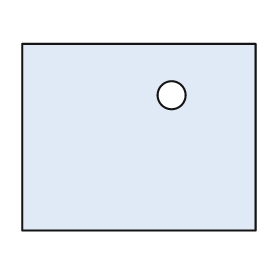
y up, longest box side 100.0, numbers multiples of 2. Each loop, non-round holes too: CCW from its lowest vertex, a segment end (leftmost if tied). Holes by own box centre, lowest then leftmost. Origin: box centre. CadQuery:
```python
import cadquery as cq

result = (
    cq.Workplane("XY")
    .moveTo(-50.0, -40.0)
    .lineTo(50.0, -40.0)
    .lineTo(50.0, 40.0)
    .lineTo(-50.0, 40.0)
    .close()
    .moveTo(14.0, 18.0)
    .circle(6.0)
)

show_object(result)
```